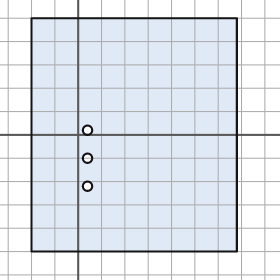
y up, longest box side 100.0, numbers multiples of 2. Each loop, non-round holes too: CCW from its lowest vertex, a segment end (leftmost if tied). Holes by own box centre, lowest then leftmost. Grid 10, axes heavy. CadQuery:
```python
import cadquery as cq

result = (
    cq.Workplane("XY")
    .moveTo(-20.0, -50.0)
    .lineTo(68.0, -50.0)
    .lineTo(68.0, 50.0)
    .lineTo(-20.0, 50.0)
    .close()
    .moveTo(4.0, -22.0)
    .circle(2.0)
    .moveTo(4.0, -10.0)
    .circle(2.0)
    .moveTo(4.0, 2.0)
    .circle(2.0)
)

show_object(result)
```